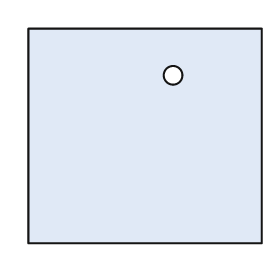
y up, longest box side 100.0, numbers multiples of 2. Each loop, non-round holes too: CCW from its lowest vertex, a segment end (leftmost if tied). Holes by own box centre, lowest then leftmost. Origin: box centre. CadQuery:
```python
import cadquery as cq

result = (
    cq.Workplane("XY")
    .moveTo(-50.0, -46.0)
    .lineTo(50.0, -46.0)
    .lineTo(50.0, 46.0)
    .lineTo(-50.0, 46.0)
    .close()
    .moveTo(12.0, 26.0)
    .circle(4.0)
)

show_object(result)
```